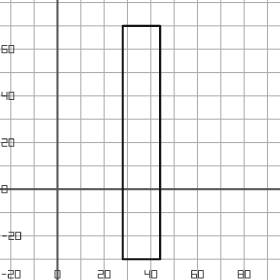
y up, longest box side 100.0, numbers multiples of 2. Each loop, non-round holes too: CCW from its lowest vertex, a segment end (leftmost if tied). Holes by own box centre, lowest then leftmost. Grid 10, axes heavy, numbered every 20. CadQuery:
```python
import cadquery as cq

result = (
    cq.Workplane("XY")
    .moveTo(28.0, -30.0)
    .lineTo(44.0, -30.0)
    .lineTo(44.0, 70.0)
    .lineTo(28.0, 70.0)
    .close()
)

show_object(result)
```